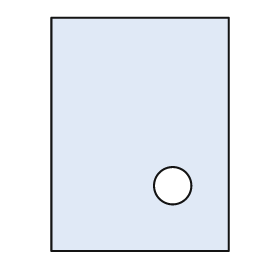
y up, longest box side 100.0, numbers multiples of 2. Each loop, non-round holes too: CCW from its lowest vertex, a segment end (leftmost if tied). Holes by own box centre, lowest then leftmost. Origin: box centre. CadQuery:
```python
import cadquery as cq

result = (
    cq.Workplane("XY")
    .moveTo(-38.0, -50.0)
    .lineTo(38.0, -50.0)
    .lineTo(38.0, 50.0)
    .lineTo(-38.0, 50.0)
    .close()
    .moveTo(14.0, -22.0)
    .circle(8.0)
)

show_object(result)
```